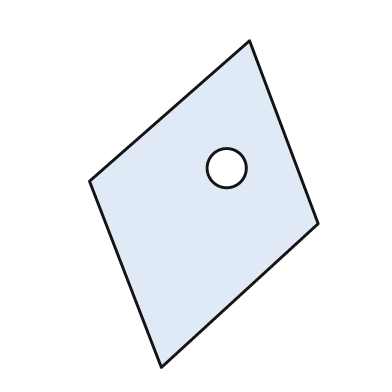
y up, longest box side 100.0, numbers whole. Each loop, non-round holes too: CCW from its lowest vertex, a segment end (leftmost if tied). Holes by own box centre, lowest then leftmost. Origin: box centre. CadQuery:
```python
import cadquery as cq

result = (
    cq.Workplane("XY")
    .moveTo(-13.0, -50.0)
    .lineTo(35.0, -6.0)
    .lineTo(14.0, 50.0)
    .lineTo(-35.0, 7.0)
    .close()
    .moveTo(7.0, 11.0)
    .circle(6.0)
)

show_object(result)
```